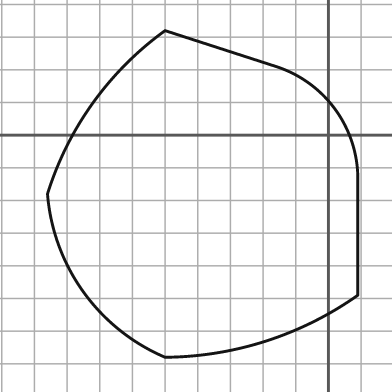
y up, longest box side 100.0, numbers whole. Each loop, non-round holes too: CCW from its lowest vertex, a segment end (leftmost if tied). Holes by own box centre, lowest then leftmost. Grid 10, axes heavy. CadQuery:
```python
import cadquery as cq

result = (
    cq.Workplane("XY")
    .moveTo(-50.0, -68.0)
    .threePointArc((-19.0, -63.0), (9.0, -49.0))
    .lineTo(9.0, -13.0)
    .threePointArc((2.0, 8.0), (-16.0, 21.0))
    .lineTo(-50.0, 32.0)
    .threePointArc((-72.0, 10.0), (-86.0, -18.0))
    .threePointArc((-75.0, -48.0), (-50.0, -68.0))
    .close()
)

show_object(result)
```